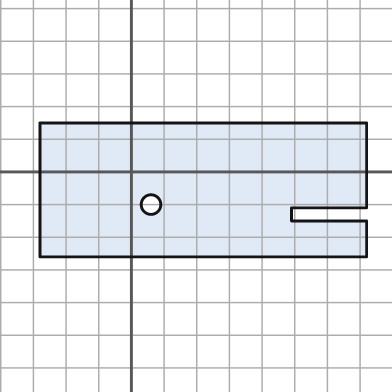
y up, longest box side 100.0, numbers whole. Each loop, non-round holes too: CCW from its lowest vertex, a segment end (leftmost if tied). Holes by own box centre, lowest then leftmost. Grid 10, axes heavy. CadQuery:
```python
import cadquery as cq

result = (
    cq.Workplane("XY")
    .moveTo(-28.0, -26.0)
    .lineTo(72.0, -26.0)
    .lineTo(72.0, -15.0)
    .lineTo(49.0, -15.0)
    .lineTo(49.0, -11.0)
    .lineTo(72.0, -11.0)
    .lineTo(72.0, 15.0)
    .lineTo(-28.0, 15.0)
    .close()
    .moveTo(6.0, -10.0)
    .circle(3.0)
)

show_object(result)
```